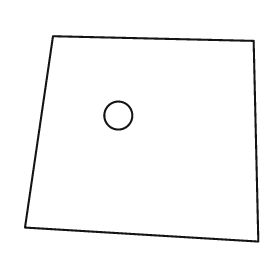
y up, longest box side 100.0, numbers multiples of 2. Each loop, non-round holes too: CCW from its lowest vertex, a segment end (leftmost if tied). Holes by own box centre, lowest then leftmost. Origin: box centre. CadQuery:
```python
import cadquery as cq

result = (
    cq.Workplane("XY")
    .moveTo(50.0, -44.0)
    .lineTo(48.0, 42.0)
    .lineTo(-38.0, 44.0)
    .lineTo(-50.0, -38.0)
    .close()
    .moveTo(-10.0, 10.0)
    .circle(6.0)
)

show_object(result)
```